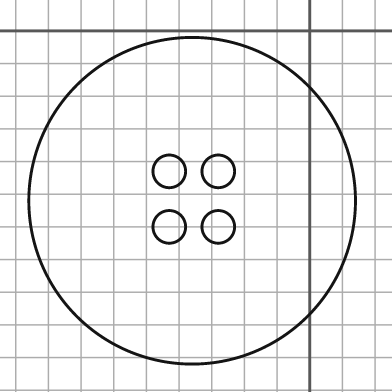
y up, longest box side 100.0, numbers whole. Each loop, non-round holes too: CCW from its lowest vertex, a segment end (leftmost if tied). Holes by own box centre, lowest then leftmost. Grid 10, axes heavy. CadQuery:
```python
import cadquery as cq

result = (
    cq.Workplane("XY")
    .moveTo(-36.0, -52.0)
    .circle(50.0)
    .moveTo(-43.0, -60.0)
    .circle(5.0)
    .moveTo(-28.0, -60.0)
    .circle(5.0)
    .moveTo(-43.0, -43.0)
    .circle(5.0)
    .moveTo(-28.0, -43.0)
    .circle(5.0)
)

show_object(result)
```